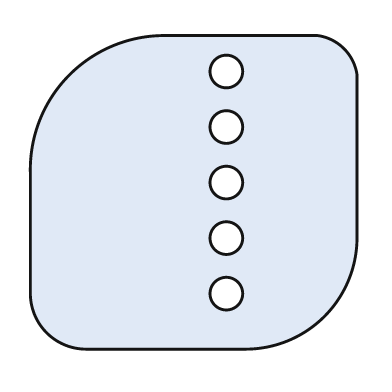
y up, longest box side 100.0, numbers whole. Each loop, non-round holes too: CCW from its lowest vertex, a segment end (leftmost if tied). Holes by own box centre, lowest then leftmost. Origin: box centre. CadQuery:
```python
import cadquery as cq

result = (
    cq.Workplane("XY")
    .moveTo(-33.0, -48.0)
    .lineTo(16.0, -48.0)
    .threePointArc((40.0, -38.0), (50.0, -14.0))
    .lineTo(50.0, 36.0)
    .threePointArc((46.0, 44.0), (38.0, 48.0))
    .lineTo(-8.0, 48.0)
    .threePointArc((-38.0, 36.0), (-50.0, 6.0))
    .lineTo(-50.0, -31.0)
    .threePointArc((-45.0, -43.0), (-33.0, -48.0))
    .close()
    .moveTo(10.0, -31.0)
    .circle(5.0)
    .moveTo(10.0, -14.0)
    .circle(5.0)
    .moveTo(10.0, 3.0)
    .circle(5.0)
    .moveTo(10.0, 20.0)
    .circle(5.0)
    .moveTo(10.0, 37.0)
    .circle(5.0)
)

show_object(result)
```